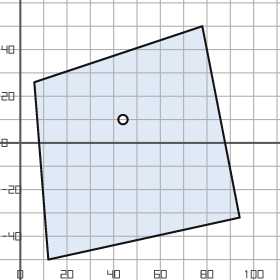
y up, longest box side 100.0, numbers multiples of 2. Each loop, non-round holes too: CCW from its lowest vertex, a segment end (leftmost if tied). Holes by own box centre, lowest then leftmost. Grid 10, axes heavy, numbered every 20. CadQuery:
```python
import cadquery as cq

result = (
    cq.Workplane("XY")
    .moveTo(12.0, -50.0)
    .lineTo(94.0, -32.0)
    .lineTo(78.0, 50.0)
    .lineTo(6.0, 26.0)
    .close()
    .moveTo(44.0, 10.0)
    .circle(2.0)
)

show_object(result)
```